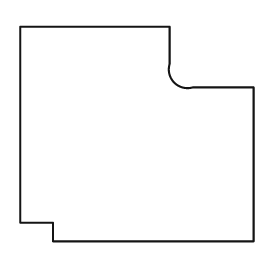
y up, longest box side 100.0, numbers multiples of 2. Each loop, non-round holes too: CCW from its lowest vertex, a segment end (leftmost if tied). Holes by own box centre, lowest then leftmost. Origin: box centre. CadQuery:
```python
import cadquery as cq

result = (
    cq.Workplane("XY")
    .moveTo(-36.0, -46.0)
    .lineTo(50.0, -46.0)
    .lineTo(50.0, 20.0)
    .lineTo(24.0, 20.0)
    .threePointArc((16.0, 22.0), (14.0, 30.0))
    .lineTo(14.0, 46.0)
    .lineTo(-50.0, 46.0)
    .lineTo(-50.0, -38.0)
    .lineTo(-36.0, -38.0)
    .close()
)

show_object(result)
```